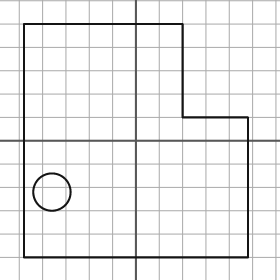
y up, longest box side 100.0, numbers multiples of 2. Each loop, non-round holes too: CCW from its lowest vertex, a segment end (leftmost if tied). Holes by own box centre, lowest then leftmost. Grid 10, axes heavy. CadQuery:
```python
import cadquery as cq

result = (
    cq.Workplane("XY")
    .moveTo(-48.0, -50.0)
    .lineTo(48.0, -50.0)
    .lineTo(48.0, 10.0)
    .lineTo(20.0, 10.0)
    .lineTo(20.0, 50.0)
    .lineTo(-48.0, 50.0)
    .close()
    .moveTo(-36.0, -22.0)
    .circle(8.0)
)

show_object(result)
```